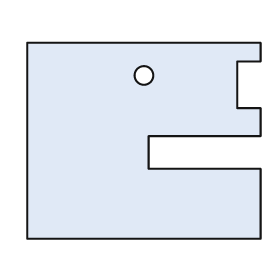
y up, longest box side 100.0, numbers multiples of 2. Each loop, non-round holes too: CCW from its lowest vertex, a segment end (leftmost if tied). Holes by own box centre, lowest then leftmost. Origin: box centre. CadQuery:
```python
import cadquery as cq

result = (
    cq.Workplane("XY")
    .moveTo(-50.0, -42.0)
    .lineTo(50.0, -42.0)
    .lineTo(50.0, -12.0)
    .lineTo(2.0, -12.0)
    .lineTo(2.0, 2.0)
    .lineTo(50.0, 2.0)
    .lineTo(50.0, 14.0)
    .lineTo(40.0, 14.0)
    .lineTo(40.0, 34.0)
    .lineTo(50.0, 34.0)
    .lineTo(50.0, 42.0)
    .lineTo(-50.0, 42.0)
    .close()
    .moveTo(0.0, 28.0)
    .circle(4.0)
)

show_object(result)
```